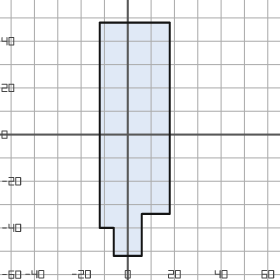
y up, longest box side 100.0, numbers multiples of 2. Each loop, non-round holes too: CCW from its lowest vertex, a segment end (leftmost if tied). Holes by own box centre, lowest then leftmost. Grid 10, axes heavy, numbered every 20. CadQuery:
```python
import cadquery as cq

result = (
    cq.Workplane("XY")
    .moveTo(-6.0, -52.0)
    .lineTo(6.0, -52.0)
    .lineTo(6.0, -34.0)
    .lineTo(18.0, -34.0)
    .lineTo(18.0, 48.0)
    .lineTo(-12.0, 48.0)
    .lineTo(-12.0, -40.0)
    .lineTo(-6.0, -40.0)
    .close()
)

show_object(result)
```